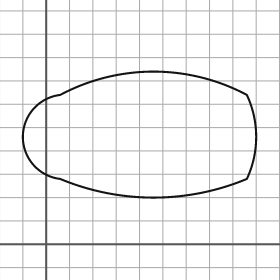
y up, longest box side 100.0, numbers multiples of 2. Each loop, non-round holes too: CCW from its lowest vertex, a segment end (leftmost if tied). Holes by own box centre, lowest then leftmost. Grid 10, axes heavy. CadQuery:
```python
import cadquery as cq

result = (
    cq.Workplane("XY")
    .moveTo(6.0, 28.0)
    .threePointArc((46.0, 20.0), (86.0, 28.0))
    .threePointArc((90.0, 46.0), (86.0, 64.0))
    .threePointArc((46.0, 74.0), (6.0, 64.0))
    .threePointArc((-10.0, 46.0), (6.0, 28.0))
    .close()
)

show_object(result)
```